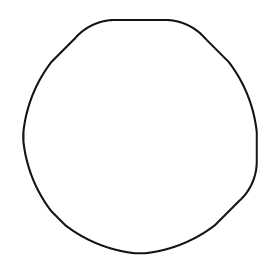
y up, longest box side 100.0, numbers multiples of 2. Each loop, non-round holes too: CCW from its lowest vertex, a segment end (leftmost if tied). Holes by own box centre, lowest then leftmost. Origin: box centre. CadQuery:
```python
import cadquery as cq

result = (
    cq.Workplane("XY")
    .moveTo(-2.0, -50.0)
    .lineTo(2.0, -50.0)
    .threePointArc((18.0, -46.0), (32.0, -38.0))
    .lineTo(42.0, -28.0)
    .threePointArc((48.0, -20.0), (50.0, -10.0))
    .lineTo(50.0, 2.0)
    .threePointArc((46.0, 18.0), (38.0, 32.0))
    .lineTo(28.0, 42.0)
    .threePointArc((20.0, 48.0), (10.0, 50.0))
    .lineTo(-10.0, 50.0)
    .threePointArc((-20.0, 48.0), (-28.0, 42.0))
    .lineTo(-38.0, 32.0)
    .threePointArc((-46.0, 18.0), (-50.0, 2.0))
    .lineTo(-50.0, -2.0)
    .threePointArc((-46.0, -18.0), (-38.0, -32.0))
    .lineTo(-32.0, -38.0)
    .threePointArc((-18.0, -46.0), (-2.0, -50.0))
    .close()
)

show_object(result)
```